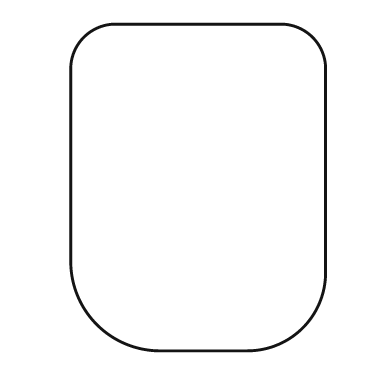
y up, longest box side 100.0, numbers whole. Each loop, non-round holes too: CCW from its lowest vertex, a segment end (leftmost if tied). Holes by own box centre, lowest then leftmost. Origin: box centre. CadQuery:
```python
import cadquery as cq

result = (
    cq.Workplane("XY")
    .moveTo(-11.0, -50.0)
    .lineTo(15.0, -50.0)
    .threePointArc((32.0, -43.0), (39.0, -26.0))
    .lineTo(39.0, 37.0)
    .threePointArc((35.0, 46.0), (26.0, 50.0))
    .lineTo(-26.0, 50.0)
    .threePointArc((-35.0, 46.0), (-39.0, 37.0))
    .lineTo(-39.0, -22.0)
    .threePointArc((-31.0, -42.0), (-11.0, -50.0))
    .close()
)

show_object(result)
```